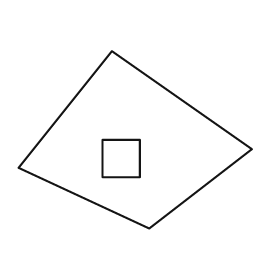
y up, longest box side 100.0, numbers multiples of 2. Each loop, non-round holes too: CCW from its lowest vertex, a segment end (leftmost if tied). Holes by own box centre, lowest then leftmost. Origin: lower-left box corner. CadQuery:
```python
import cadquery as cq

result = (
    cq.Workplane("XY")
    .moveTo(56.0, 0.0)
    .lineTo(100.0, 34.0)
    .lineTo(40.0, 76.0)
    .lineTo(0.0, 26.0)
    .close()
    .moveTo(36.0, 22.0)
    .lineTo(52.0, 22.0)
    .lineTo(52.0, 38.0)
    .lineTo(36.0, 38.0)
    .close()
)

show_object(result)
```